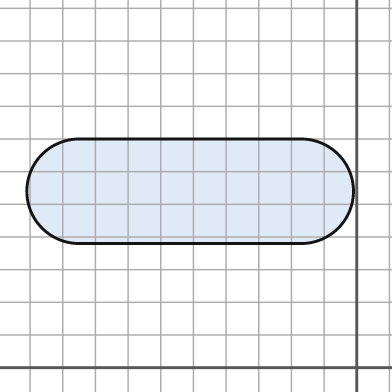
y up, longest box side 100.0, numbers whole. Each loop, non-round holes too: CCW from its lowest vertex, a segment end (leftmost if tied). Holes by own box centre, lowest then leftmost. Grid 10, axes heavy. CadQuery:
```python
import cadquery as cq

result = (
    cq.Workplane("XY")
    .moveTo(-85.0, 38.0)
    .lineTo(-17.0, 38.0)
    .threePointArc((-1.0, 54.0), (-17.0, 70.0))
    .lineTo(-85.0, 70.0)
    .threePointArc((-101.0, 54.0), (-85.0, 38.0))
    .close()
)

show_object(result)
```